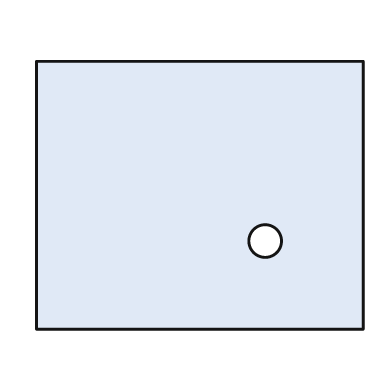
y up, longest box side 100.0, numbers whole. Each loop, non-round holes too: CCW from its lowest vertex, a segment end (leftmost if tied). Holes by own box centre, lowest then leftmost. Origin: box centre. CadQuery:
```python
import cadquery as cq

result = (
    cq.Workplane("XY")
    .moveTo(-50.0, -41.0)
    .lineTo(50.0, -41.0)
    .lineTo(50.0, 41.0)
    .lineTo(-50.0, 41.0)
    .close()
    .moveTo(20.0, -14.0)
    .circle(5.0)
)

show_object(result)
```